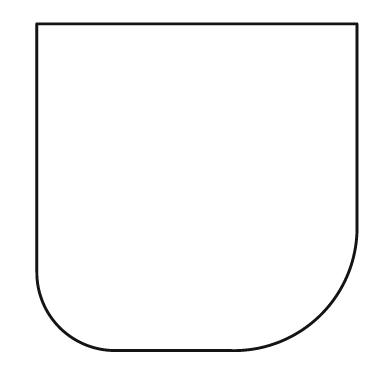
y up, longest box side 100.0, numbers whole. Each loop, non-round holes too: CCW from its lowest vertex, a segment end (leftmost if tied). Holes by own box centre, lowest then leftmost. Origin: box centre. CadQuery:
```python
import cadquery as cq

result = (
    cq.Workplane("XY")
    .moveTo(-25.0, -50.0)
    .lineTo(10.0, -50.0)
    .threePointArc((38.0, -39.0), (49.0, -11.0))
    .lineTo(49.0, 50.0)
    .lineTo(-49.0, 50.0)
    .lineTo(-49.0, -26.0)
    .threePointArc((-42.0, -43.0), (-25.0, -50.0))
    .close()
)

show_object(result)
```